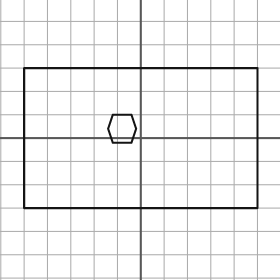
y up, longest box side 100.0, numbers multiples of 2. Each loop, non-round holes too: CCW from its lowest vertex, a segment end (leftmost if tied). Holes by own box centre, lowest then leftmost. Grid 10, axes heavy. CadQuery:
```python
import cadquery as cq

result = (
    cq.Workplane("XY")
    .moveTo(-50.0, -30.0)
    .lineTo(50.0, -30.0)
    .lineTo(50.0, 30.0)
    .lineTo(-50.0, 30.0)
    .close()
    .moveTo(-12.0, -2.0)
    .lineTo(-4.0, -2.0)
    .lineTo(-2.0, 4.0)
    .lineTo(-4.0, 10.0)
    .lineTo(-12.0, 10.0)
    .lineTo(-14.0, 4.0)
    .close()
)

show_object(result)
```